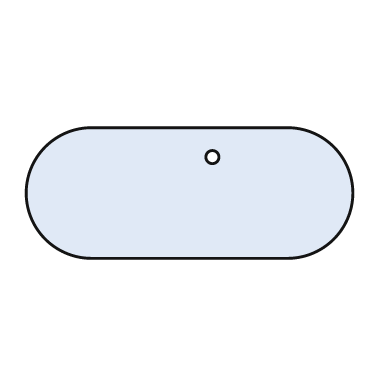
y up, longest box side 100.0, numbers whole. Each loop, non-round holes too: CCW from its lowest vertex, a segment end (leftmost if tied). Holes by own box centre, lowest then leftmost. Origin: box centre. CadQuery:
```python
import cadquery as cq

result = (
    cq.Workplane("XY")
    .moveTo(-30.0, -20.0)
    .lineTo(30.0, -20.0)
    .threePointArc((50.0, 0.0), (30.0, 20.0))
    .lineTo(-30.0, 20.0)
    .threePointArc((-50.0, 0.0), (-30.0, -20.0))
    .close()
    .moveTo(7.0, 11.0)
    .circle(2.0)
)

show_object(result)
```